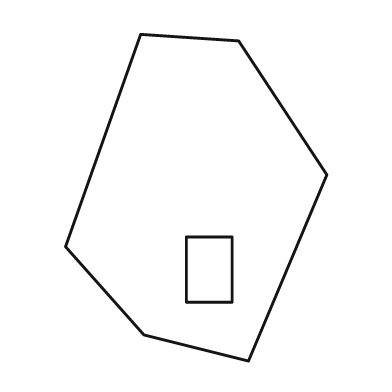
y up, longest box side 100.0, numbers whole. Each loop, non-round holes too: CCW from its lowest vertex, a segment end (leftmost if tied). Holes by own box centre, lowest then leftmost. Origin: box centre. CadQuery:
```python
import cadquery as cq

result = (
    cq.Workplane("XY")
    .moveTo(16.0, -50.0)
    .lineTo(40.0, 7.0)
    .lineTo(13.0, 48.0)
    .lineTo(-17.0, 50.0)
    .lineTo(-40.0, -15.0)
    .lineTo(-16.0, -42.0)
    .close()
    .moveTo(-3.0, -32.0)
    .lineTo(11.0, -32.0)
    .lineTo(11.0, -12.0)
    .lineTo(-3.0, -12.0)
    .close()
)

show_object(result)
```